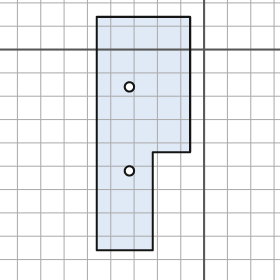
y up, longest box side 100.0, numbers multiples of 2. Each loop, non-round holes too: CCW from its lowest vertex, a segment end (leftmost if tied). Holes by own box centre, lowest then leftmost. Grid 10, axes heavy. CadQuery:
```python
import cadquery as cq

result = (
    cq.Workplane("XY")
    .moveTo(-46.0, -86.0)
    .lineTo(-22.0, -86.0)
    .lineTo(-22.0, -44.0)
    .lineTo(-6.0, -44.0)
    .lineTo(-6.0, 14.0)
    .lineTo(-46.0, 14.0)
    .close()
    .moveTo(-32.0, -52.0)
    .circle(2.0)
    .moveTo(-32.0, -16.0)
    .circle(2.0)
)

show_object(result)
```